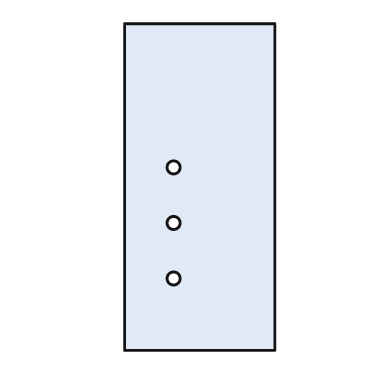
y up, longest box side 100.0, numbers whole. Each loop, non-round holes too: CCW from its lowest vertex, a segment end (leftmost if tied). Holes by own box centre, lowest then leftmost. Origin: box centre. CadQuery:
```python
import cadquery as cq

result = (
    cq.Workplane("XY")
    .moveTo(-23.0, -50.0)
    .lineTo(23.0, -50.0)
    .lineTo(23.0, 50.0)
    .lineTo(-23.0, 50.0)
    .close()
    .moveTo(-8.0, -28.0)
    .circle(2.0)
    .moveTo(-8.0, -11.0)
    .circle(2.0)
    .moveTo(-8.0, 6.0)
    .circle(2.0)
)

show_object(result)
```